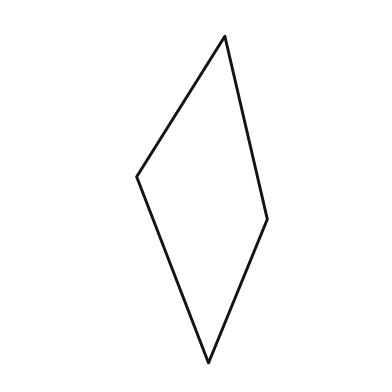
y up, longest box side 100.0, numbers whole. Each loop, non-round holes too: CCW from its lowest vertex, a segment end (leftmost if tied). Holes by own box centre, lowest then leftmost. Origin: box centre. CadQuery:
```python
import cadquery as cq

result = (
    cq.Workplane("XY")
    .moveTo(2.0, -50.0)
    .lineTo(20.0, -6.0)
    .lineTo(7.0, 50.0)
    .lineTo(-20.0, 7.0)
    .close()
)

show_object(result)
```